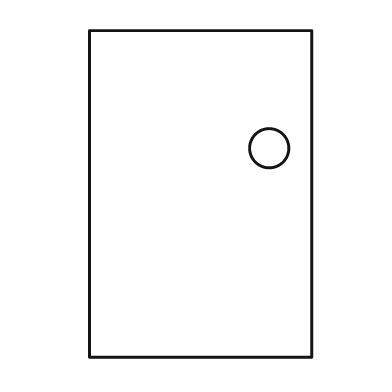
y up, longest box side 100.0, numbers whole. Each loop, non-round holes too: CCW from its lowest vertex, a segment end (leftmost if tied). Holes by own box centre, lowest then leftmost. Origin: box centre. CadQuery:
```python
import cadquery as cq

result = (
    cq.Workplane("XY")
    .moveTo(-34.0, -50.0)
    .lineTo(34.0, -50.0)
    .lineTo(34.0, 50.0)
    .lineTo(-34.0, 50.0)
    .close()
    .moveTo(21.0, 14.0)
    .circle(6.0)
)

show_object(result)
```